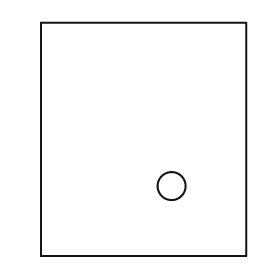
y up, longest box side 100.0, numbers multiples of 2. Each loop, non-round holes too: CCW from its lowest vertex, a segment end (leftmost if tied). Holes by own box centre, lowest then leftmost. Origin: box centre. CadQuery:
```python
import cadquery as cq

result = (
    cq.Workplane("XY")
    .moveTo(-44.0, -50.0)
    .lineTo(44.0, -50.0)
    .lineTo(44.0, 50.0)
    .lineTo(-44.0, 50.0)
    .close()
    .moveTo(12.0, -20.0)
    .circle(6.0)
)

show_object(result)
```